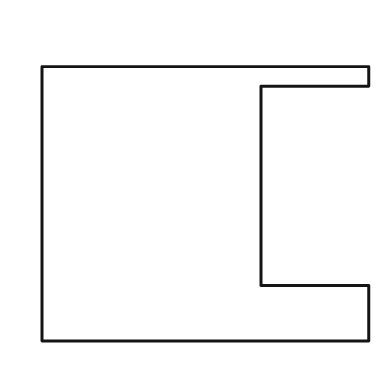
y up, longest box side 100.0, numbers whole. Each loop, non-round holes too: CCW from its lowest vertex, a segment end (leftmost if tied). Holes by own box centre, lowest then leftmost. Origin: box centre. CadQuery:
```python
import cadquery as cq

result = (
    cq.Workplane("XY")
    .moveTo(-50.0, -42.0)
    .lineTo(50.0, -42.0)
    .lineTo(50.0, -25.0)
    .lineTo(17.0, -25.0)
    .lineTo(17.0, 36.0)
    .lineTo(50.0, 36.0)
    .lineTo(50.0, 42.0)
    .lineTo(-50.0, 42.0)
    .close()
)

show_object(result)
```